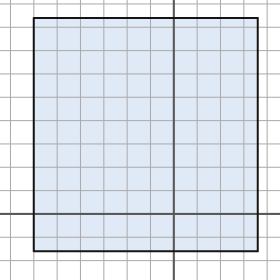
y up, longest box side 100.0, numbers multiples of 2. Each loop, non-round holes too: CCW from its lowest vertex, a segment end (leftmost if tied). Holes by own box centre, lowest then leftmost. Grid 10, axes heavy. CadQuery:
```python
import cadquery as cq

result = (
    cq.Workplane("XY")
    .moveTo(-60.0, -16.0)
    .lineTo(36.0, -16.0)
    .lineTo(36.0, 84.0)
    .lineTo(-60.0, 84.0)
    .close()
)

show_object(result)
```